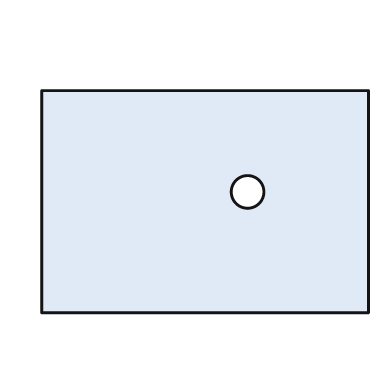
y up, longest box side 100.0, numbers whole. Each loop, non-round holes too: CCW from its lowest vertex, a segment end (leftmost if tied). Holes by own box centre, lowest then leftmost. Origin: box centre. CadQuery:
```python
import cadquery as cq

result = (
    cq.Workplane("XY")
    .moveTo(-50.0, -34.0)
    .lineTo(50.0, -34.0)
    .lineTo(50.0, 34.0)
    .lineTo(-50.0, 34.0)
    .close()
    .moveTo(13.0, 3.0)
    .circle(5.0)
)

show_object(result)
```